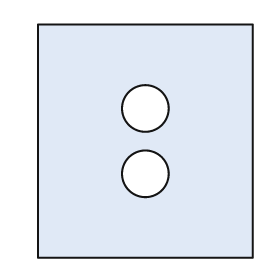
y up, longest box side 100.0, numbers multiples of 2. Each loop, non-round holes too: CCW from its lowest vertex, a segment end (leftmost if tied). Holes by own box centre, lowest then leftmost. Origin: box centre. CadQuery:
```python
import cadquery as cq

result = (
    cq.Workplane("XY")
    .moveTo(-46.0, -50.0)
    .lineTo(46.0, -50.0)
    .lineTo(46.0, 50.0)
    .lineTo(-46.0, 50.0)
    .close()
    .moveTo(0.0, -14.0)
    .circle(10.0)
    .moveTo(0.0, 14.0)
    .circle(10.0)
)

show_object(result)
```